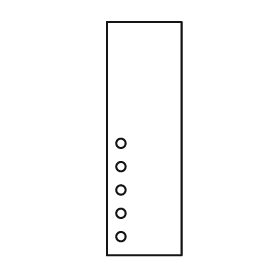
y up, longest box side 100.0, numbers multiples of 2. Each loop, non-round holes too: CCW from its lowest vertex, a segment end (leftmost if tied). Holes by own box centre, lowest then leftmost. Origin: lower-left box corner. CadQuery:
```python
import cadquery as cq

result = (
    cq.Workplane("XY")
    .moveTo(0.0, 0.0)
    .lineTo(32.0, 0.0)
    .lineTo(32.0, 100.0)
    .lineTo(0.0, 100.0)
    .close()
    .moveTo(6.0, 8.0)
    .circle(2.0)
    .moveTo(6.0, 18.0)
    .circle(2.0)
    .moveTo(6.0, 28.0)
    .circle(2.0)
    .moveTo(6.0, 38.0)
    .circle(2.0)
    .moveTo(6.0, 48.0)
    .circle(2.0)
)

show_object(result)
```